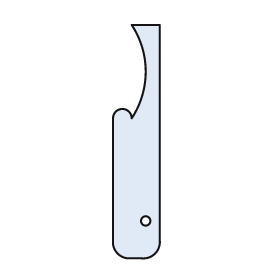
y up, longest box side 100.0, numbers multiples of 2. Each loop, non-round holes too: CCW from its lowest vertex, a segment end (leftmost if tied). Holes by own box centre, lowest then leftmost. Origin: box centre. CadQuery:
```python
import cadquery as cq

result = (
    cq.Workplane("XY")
    .moveTo(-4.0, -50.0)
    .lineTo(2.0, -50.0)
    .threePointArc((8.0, -48.0), (10.0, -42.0))
    .lineTo(10.0, 50.0)
    .lineTo(-2.0, 50.0)
    .threePointArc((4.0, 30.0), (-2.0, 10.0))
    .threePointArc((-6.0, 14.0), (-10.0, 10.0))
    .lineTo(-10.0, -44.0)
    .threePointArc((-8.0, -48.0), (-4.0, -50.0))
    .close()
    .moveTo(4.0, -34.0)
    .circle(2.0)
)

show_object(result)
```